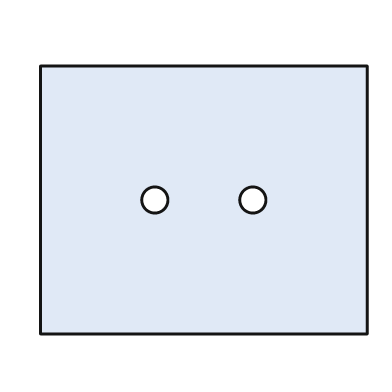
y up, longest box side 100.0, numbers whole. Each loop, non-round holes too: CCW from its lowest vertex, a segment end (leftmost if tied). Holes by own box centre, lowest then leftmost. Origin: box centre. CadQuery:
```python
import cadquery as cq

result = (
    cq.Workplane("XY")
    .moveTo(-50.0, -41.0)
    .lineTo(50.0, -41.0)
    .lineTo(50.0, 41.0)
    .lineTo(-50.0, 41.0)
    .close()
    .moveTo(-15.0, 0.0)
    .circle(4.0)
    .moveTo(15.0, 0.0)
    .circle(4.0)
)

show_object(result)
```